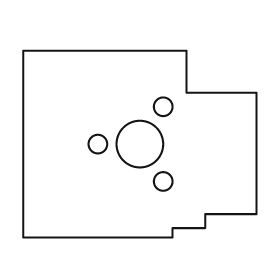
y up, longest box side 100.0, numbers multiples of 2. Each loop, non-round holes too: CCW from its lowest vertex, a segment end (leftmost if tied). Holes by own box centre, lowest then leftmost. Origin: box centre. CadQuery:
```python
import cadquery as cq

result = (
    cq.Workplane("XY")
    .moveTo(-50.0, -40.0)
    .lineTo(14.0, -40.0)
    .lineTo(14.0, -36.0)
    .lineTo(28.0, -36.0)
    .lineTo(28.0, -30.0)
    .lineTo(50.0, -30.0)
    .lineTo(50.0, 22.0)
    .lineTo(20.0, 22.0)
    .lineTo(20.0, 40.0)
    .lineTo(-50.0, 40.0)
    .close()
    .moveTo(10.0, -16.0)
    .circle(4.0)
    .moveTo(-18.0, 0.0)
    .circle(4.0)
    .moveTo(0.0, 0.0)
    .circle(10.0)
    .moveTo(10.0, 16.0)
    .circle(4.0)
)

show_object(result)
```